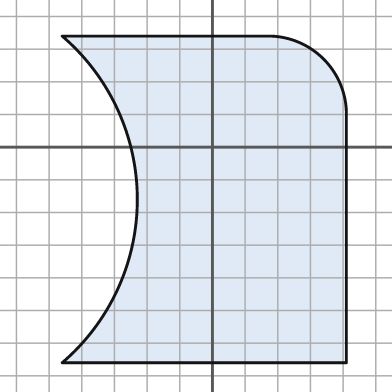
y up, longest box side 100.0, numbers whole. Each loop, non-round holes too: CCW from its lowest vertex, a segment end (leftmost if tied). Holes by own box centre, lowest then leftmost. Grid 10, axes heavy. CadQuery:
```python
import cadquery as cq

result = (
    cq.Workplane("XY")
    .moveTo(-46.0, -66.0)
    .lineTo(41.0, -66.0)
    .lineTo(41.0, 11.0)
    .threePointArc((34.0, 27.0), (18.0, 34.0))
    .lineTo(-46.0, 34.0)
    .threePointArc((-23.0, -16.0), (-46.0, -66.0))
    .close()
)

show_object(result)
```